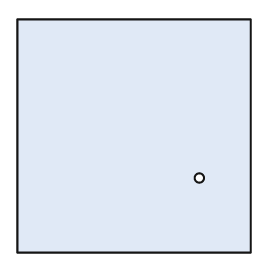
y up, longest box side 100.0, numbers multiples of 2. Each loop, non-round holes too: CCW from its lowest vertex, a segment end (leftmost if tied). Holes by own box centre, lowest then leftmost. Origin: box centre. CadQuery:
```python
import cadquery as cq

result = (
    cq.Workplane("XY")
    .moveTo(-50.0, -50.0)
    .lineTo(50.0, -50.0)
    .lineTo(50.0, 50.0)
    .lineTo(-50.0, 50.0)
    .close()
    .moveTo(28.0, -18.0)
    .circle(2.0)
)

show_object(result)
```